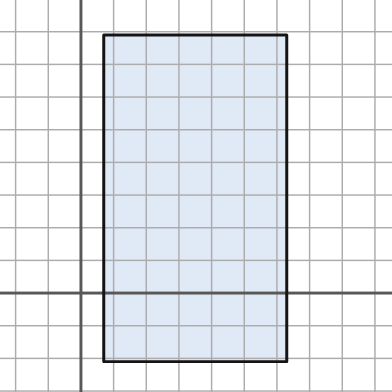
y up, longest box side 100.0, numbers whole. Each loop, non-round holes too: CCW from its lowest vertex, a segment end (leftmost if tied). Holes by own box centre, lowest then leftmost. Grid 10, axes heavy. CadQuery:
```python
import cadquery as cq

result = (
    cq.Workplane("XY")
    .moveTo(7.0, -21.0)
    .lineTo(63.0, -21.0)
    .lineTo(63.0, 79.0)
    .lineTo(7.0, 79.0)
    .close()
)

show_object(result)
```